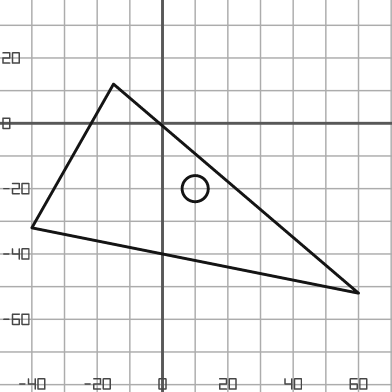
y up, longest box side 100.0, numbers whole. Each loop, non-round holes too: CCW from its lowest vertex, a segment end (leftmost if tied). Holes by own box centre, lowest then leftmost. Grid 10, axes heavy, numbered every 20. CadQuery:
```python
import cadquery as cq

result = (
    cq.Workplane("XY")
    .moveTo(60.0, -52.0)
    .lineTo(-15.0, 12.0)
    .lineTo(-40.0, -32.0)
    .close()
    .moveTo(10.0, -20.0)
    .circle(4.0)
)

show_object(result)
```